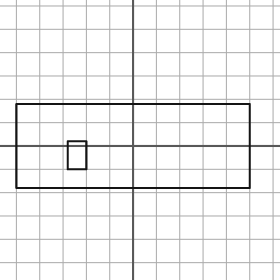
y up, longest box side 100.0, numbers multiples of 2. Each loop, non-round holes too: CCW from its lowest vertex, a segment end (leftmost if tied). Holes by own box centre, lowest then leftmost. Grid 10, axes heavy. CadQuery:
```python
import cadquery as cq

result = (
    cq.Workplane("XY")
    .moveTo(-50.0, -18.0)
    .lineTo(50.0, -18.0)
    .lineTo(50.0, 18.0)
    .lineTo(-50.0, 18.0)
    .close()
    .moveTo(-28.0, -10.0)
    .lineTo(-20.0, -10.0)
    .lineTo(-20.0, 2.0)
    .lineTo(-28.0, 2.0)
    .close()
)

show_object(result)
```